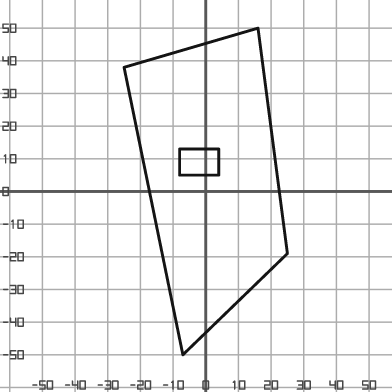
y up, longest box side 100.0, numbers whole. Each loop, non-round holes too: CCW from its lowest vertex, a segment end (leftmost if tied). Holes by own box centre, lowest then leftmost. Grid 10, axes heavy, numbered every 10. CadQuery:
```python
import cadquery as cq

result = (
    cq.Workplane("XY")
    .moveTo(-7.0, -50.0)
    .lineTo(25.0, -19.0)
    .lineTo(16.0, 50.0)
    .lineTo(-25.0, 38.0)
    .close()
    .moveTo(-8.0, 5.0)
    .lineTo(4.0, 5.0)
    .lineTo(4.0, 13.0)
    .lineTo(-8.0, 13.0)
    .close()
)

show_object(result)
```